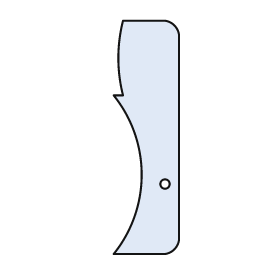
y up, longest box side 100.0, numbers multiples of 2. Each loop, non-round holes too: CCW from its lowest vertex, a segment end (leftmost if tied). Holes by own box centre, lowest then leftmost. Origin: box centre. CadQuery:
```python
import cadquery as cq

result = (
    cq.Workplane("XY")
    .moveTo(-14.0, -50.0)
    .lineTo(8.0, -50.0)
    .threePointArc((12.0, -48.0), (14.0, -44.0))
    .lineTo(14.0, 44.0)
    .threePointArc((12.0, 48.0), (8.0, 50.0))
    .lineTo(-10.0, 50.0)
    .threePointArc((-12.0, 34.0), (-10.0, 18.0))
    .lineTo(-14.0, 18.0)
    .threePointArc((-2.0, -16.0), (-14.0, -50.0))
    .close()
    .moveTo(8.0, -20.0)
    .circle(2.0)
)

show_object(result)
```